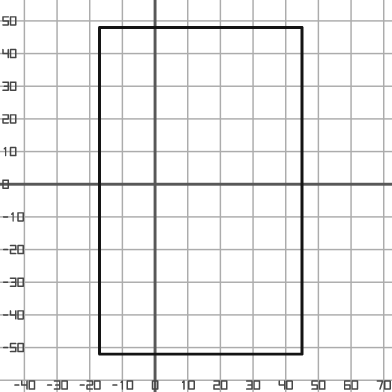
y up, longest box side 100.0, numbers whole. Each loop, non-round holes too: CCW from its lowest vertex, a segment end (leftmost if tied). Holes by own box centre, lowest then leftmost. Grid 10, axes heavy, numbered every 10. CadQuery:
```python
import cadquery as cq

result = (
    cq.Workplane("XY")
    .moveTo(-17.0, -52.0)
    .lineTo(45.0, -52.0)
    .lineTo(45.0, 48.0)
    .lineTo(-17.0, 48.0)
    .close()
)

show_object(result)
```